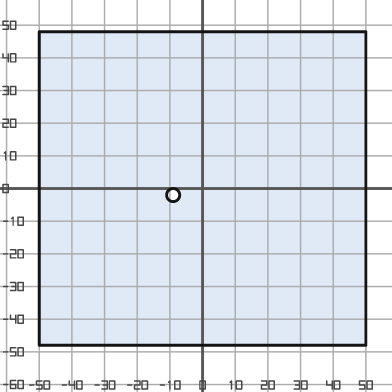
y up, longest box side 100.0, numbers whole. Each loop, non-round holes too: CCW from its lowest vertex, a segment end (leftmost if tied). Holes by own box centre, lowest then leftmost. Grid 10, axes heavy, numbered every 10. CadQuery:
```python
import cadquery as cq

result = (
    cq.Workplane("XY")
    .moveTo(-50.0, -48.0)
    .lineTo(50.0, -48.0)
    .lineTo(50.0, 48.0)
    .lineTo(-50.0, 48.0)
    .close()
    .moveTo(-9.0, -2.0)
    .circle(2.0)
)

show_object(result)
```